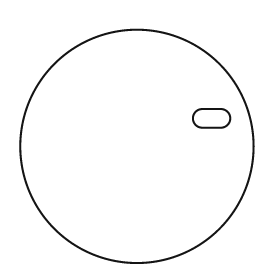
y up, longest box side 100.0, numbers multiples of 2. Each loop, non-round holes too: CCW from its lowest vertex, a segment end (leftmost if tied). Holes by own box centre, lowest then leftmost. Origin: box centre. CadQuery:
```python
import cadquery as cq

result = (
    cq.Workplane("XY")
    .moveTo(0.0, 0.0)
    .circle(50.0)
    .moveTo(28.0, 8.0)
    .lineTo(36.0, 8.0)
    .threePointArc((40.0, 12.0), (36.0, 16.0))
    .lineTo(28.0, 16.0)
    .threePointArc((24.0, 12.0), (28.0, 8.0))
    .close()
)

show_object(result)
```